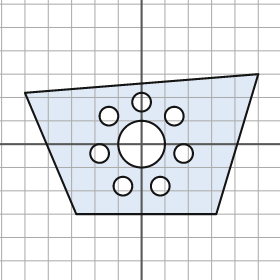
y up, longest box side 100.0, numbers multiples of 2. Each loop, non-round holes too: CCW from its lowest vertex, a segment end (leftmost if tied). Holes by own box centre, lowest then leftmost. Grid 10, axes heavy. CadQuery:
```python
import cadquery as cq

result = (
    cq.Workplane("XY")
    .moveTo(-28.0, -30.0)
    .lineTo(32.0, -30.0)
    .lineTo(50.0, 30.0)
    .lineTo(-50.0, 22.0)
    .close()
    .moveTo(-8.0, -18.0)
    .circle(4.0)
    .moveTo(8.0, -18.0)
    .circle(4.0)
    .moveTo(-18.0, -4.0)
    .circle(4.0)
    .moveTo(18.0, -4.0)
    .circle(4.0)
    .moveTo(0.0, 0.0)
    .circle(10.0)
    .moveTo(-14.0, 12.0)
    .circle(4.0)
    .moveTo(14.0, 12.0)
    .circle(4.0)
    .moveTo(0.0, 18.0)
    .circle(4.0)
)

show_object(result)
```